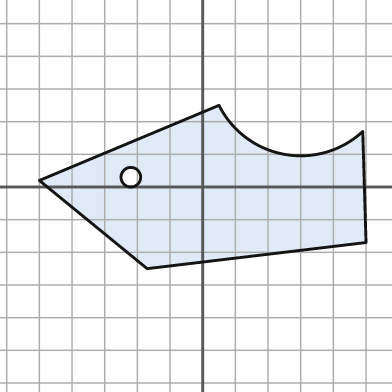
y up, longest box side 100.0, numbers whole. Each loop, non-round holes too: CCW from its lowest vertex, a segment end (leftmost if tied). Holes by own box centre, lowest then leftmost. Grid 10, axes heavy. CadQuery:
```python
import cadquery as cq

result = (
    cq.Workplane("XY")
    .moveTo(-17.0, -25.0)
    .lineTo(50.0, -17.0)
    .lineTo(49.0, 17.0)
    .threePointArc((25.0, 10.0), (5.0, 25.0))
    .lineTo(-50.0, 2.0)
    .close()
    .moveTo(-22.0, 3.0)
    .circle(3.0)
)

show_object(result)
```